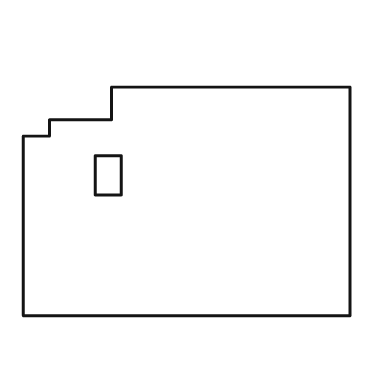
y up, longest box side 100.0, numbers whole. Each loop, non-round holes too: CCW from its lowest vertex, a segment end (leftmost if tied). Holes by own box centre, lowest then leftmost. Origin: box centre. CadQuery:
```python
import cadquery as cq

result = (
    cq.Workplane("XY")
    .moveTo(-50.0, -35.0)
    .lineTo(50.0, -35.0)
    .lineTo(50.0, 35.0)
    .lineTo(-23.0, 35.0)
    .lineTo(-23.0, 25.0)
    .lineTo(-42.0, 25.0)
    .lineTo(-42.0, 20.0)
    .lineTo(-50.0, 20.0)
    .close()
    .moveTo(-28.0, 2.0)
    .lineTo(-20.0, 2.0)
    .lineTo(-20.0, 14.0)
    .lineTo(-28.0, 14.0)
    .close()
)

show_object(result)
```